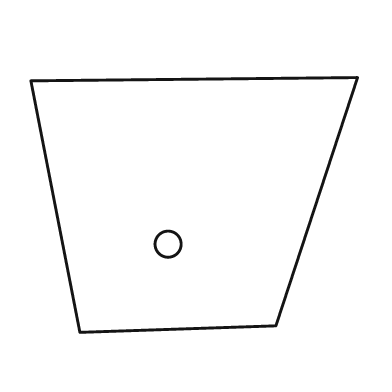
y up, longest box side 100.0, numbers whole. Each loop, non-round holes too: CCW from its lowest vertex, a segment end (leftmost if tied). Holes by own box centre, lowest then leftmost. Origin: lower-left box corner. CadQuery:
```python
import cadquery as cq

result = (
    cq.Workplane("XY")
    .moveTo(15.0, 0.0)
    .lineTo(75.0, 2.0)
    .lineTo(100.0, 78.0)
    .lineTo(0.0, 77.0)
    .close()
    .moveTo(42.0, 27.0)
    .circle(4.0)
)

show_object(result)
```